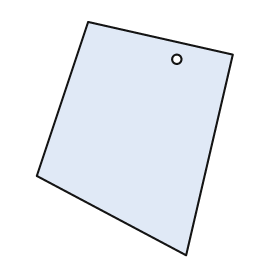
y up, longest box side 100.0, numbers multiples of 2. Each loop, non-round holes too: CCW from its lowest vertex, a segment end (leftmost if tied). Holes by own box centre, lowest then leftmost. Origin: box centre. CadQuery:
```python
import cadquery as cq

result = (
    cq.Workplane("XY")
    .moveTo(22.0, -50.0)
    .lineTo(42.0, 36.0)
    .lineTo(-20.0, 50.0)
    .lineTo(-42.0, -16.0)
    .close()
    .moveTo(18.0, 34.0)
    .circle(2.0)
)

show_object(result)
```